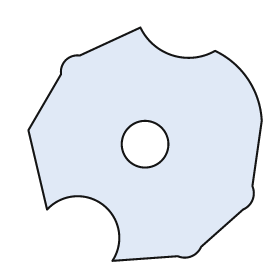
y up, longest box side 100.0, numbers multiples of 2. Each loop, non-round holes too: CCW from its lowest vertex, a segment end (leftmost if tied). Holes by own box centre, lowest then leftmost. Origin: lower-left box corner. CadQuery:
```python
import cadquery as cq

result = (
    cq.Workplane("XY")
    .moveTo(36.0, 0.0)
    .lineTo(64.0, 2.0)
    .threePointArc((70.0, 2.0), (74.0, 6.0))
    .lineTo(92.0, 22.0)
    .threePointArc((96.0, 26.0), (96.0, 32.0))
    .lineTo(100.0, 60.0)
    .threePointArc((94.0, 78.0), (80.0, 90.0))
    .threePointArc((62.0, 88.0), (48.0, 100.0))
    .lineTo(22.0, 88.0)
    .threePointArc((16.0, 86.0), (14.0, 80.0))
    .lineTo(0.0, 56.0)
    .lineTo(8.0, 22.0)
    .threePointArc((32.0, 24.0), (36.0, 0.0))
    .close()
    .moveTo(50.0, 50.0)
    .circle(10.0)
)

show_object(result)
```